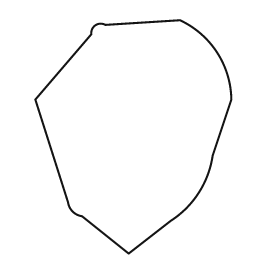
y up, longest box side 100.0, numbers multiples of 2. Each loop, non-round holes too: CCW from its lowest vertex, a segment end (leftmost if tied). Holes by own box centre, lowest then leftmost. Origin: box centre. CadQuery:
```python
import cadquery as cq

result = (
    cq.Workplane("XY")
    .moveTo(-2.0, -50.0)
    .lineTo(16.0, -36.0)
    .threePointArc((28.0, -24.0), (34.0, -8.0))
    .lineTo(42.0, 16.0)
    .threePointArc((36.0, 36.0), (20.0, 50.0))
    .lineTo(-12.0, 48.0)
    .threePointArc((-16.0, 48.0), (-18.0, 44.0))
    .lineTo(-42.0, 16.0)
    .lineTo(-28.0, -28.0)
    .threePointArc((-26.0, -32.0), (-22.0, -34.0))
    .close()
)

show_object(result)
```